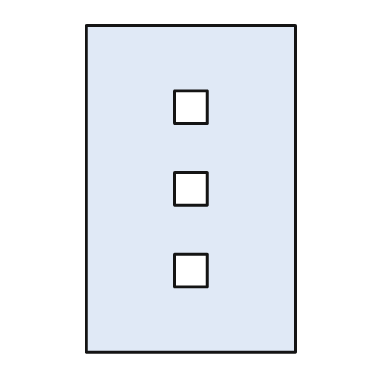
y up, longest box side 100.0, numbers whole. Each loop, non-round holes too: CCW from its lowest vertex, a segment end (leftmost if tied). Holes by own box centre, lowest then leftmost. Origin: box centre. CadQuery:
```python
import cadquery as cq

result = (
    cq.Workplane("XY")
    .moveTo(-32.0, -50.0)
    .lineTo(32.0, -50.0)
    .lineTo(32.0, 50.0)
    .lineTo(-32.0, 50.0)
    .close()
    .moveTo(-5.0, -30.0)
    .lineTo(5.0, -30.0)
    .lineTo(5.0, -20.0)
    .lineTo(-5.0, -20.0)
    .close()
    .moveTo(-5.0, -5.0)
    .lineTo(5.0, -5.0)
    .lineTo(5.0, 5.0)
    .lineTo(-5.0, 5.0)
    .close()
    .moveTo(-5.0, 20.0)
    .lineTo(5.0, 20.0)
    .lineTo(5.0, 30.0)
    .lineTo(-5.0, 30.0)
    .close()
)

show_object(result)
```